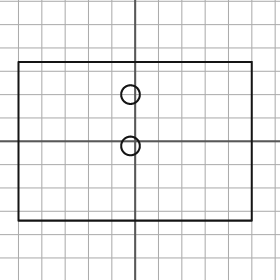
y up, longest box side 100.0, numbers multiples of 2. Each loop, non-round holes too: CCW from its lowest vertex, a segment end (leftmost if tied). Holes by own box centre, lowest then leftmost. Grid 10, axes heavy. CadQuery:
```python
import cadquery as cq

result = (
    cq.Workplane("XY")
    .moveTo(-50.0, -34.0)
    .lineTo(50.0, -34.0)
    .lineTo(50.0, 34.0)
    .lineTo(-50.0, 34.0)
    .close()
    .moveTo(-2.0, -2.0)
    .circle(4.0)
    .moveTo(-2.0, 20.0)
    .circle(4.0)
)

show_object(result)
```